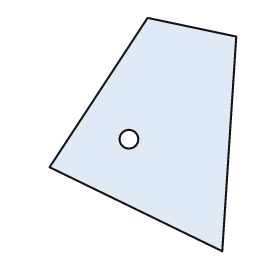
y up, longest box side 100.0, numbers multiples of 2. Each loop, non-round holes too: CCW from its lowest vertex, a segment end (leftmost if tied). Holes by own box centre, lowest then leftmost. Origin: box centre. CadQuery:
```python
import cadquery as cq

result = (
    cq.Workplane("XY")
    .moveTo(34.0, -50.0)
    .lineTo(40.0, 42.0)
    .lineTo(2.0, 50.0)
    .lineTo(-40.0, -14.0)
    .close()
    .moveTo(-6.0, -2.0)
    .circle(4.0)
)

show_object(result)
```